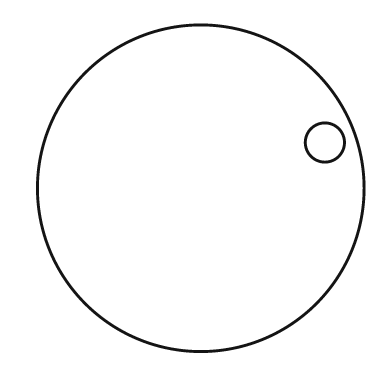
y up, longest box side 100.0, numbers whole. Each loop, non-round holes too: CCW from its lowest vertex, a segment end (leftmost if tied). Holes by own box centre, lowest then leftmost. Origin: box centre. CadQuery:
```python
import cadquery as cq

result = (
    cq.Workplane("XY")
    .moveTo(0.0, 0.0)
    .circle(50.0)
    .moveTo(38.0, 14.0)
    .circle(6.0)
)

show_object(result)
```